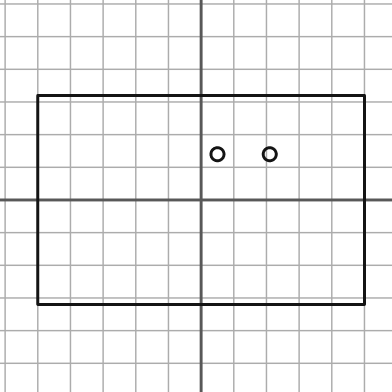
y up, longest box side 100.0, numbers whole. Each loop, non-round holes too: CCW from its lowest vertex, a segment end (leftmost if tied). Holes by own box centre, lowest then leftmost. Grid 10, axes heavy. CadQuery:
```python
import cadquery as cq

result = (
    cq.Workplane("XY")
    .moveTo(-50.0, -32.0)
    .lineTo(50.0, -32.0)
    .lineTo(50.0, 32.0)
    .lineTo(-50.0, 32.0)
    .close()
    .moveTo(5.0, 14.0)
    .circle(2.0)
    .moveTo(21.0, 14.0)
    .circle(2.0)
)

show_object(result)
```